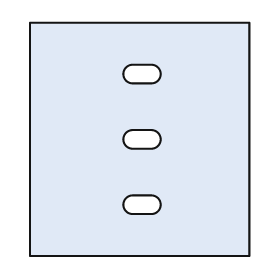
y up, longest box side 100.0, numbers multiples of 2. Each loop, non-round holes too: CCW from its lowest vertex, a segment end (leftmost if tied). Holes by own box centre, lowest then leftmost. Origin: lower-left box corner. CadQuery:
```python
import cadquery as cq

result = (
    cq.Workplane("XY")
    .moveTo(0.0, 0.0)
    .lineTo(94.0, 0.0)
    .lineTo(94.0, 100.0)
    .lineTo(0.0, 100.0)
    .close()
    .moveTo(44.0, 18.0)
    .lineTo(52.0, 18.0)
    .threePointArc((56.0, 22.0), (52.0, 26.0))
    .lineTo(44.0, 26.0)
    .threePointArc((40.0, 22.0), (44.0, 18.0))
    .close()
    .moveTo(44.0, 46.0)
    .lineTo(52.0, 46.0)
    .threePointArc((56.0, 50.0), (52.0, 54.0))
    .lineTo(44.0, 54.0)
    .threePointArc((40.0, 50.0), (44.0, 46.0))
    .close()
    .moveTo(44.0, 74.0)
    .lineTo(52.0, 74.0)
    .threePointArc((56.0, 78.0), (52.0, 82.0))
    .lineTo(44.0, 82.0)
    .threePointArc((40.0, 78.0), (44.0, 74.0))
    .close()
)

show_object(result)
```